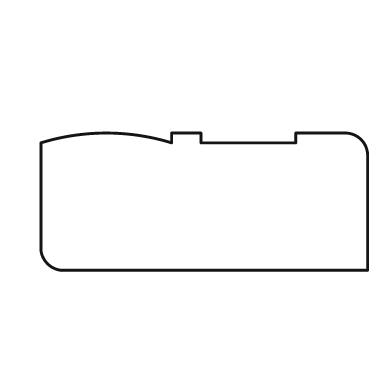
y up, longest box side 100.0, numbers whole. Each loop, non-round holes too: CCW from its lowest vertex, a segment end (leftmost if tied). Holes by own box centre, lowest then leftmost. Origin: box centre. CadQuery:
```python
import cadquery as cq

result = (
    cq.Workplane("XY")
    .moveTo(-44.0, -21.0)
    .lineTo(50.0, -21.0)
    .lineTo(50.0, 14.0)
    .threePointArc((48.0, 19.0), (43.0, 21.0))
    .lineTo(28.0, 21.0)
    .lineTo(28.0, 18.0)
    .lineTo(-1.0, 18.0)
    .lineTo(-1.0, 21.0)
    .lineTo(-10.0, 21.0)
    .lineTo(-10.0, 18.0)
    .threePointArc((-30.0, 21.0), (-50.0, 18.0))
    .lineTo(-50.0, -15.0)
    .threePointArc((-48.0, -19.0), (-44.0, -21.0))
    .close()
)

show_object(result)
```